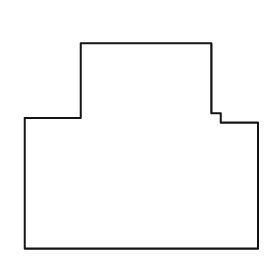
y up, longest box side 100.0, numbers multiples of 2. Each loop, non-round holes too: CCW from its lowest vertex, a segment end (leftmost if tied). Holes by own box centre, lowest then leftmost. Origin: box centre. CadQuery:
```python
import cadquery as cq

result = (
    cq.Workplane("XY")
    .moveTo(-50.0, -44.0)
    .lineTo(50.0, -44.0)
    .lineTo(50.0, 10.0)
    .lineTo(34.0, 10.0)
    .lineTo(34.0, 14.0)
    .lineTo(30.0, 14.0)
    .lineTo(30.0, 44.0)
    .lineTo(-26.0, 44.0)
    .lineTo(-26.0, 12.0)
    .lineTo(-50.0, 12.0)
    .close()
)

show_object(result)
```